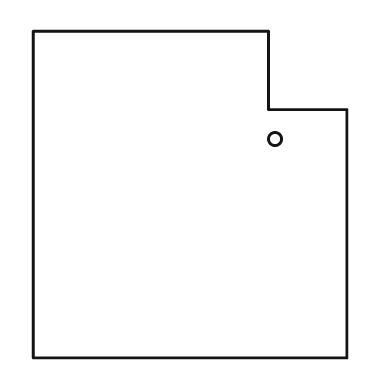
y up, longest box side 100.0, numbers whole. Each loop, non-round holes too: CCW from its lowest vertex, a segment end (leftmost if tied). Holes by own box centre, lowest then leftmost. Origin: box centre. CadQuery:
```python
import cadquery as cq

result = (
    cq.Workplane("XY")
    .moveTo(-48.0, -50.0)
    .lineTo(48.0, -50.0)
    .lineTo(48.0, 26.0)
    .lineTo(24.0, 26.0)
    .lineTo(24.0, 50.0)
    .lineTo(-48.0, 50.0)
    .close()
    .moveTo(26.0, 17.0)
    .circle(2.0)
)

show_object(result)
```